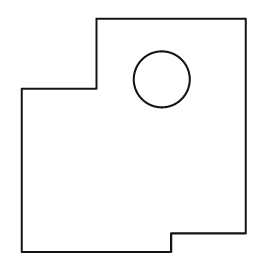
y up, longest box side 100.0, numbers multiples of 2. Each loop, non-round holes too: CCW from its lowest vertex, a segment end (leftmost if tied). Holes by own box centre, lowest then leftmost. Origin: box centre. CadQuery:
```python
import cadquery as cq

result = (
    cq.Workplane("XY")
    .moveTo(-48.0, -50.0)
    .lineTo(16.0, -50.0)
    .lineTo(16.0, -42.0)
    .lineTo(48.0, -42.0)
    .lineTo(48.0, 50.0)
    .lineTo(-16.0, 50.0)
    .lineTo(-16.0, 20.0)
    .lineTo(-48.0, 20.0)
    .close()
    .moveTo(12.0, 24.0)
    .circle(12.0)
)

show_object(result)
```